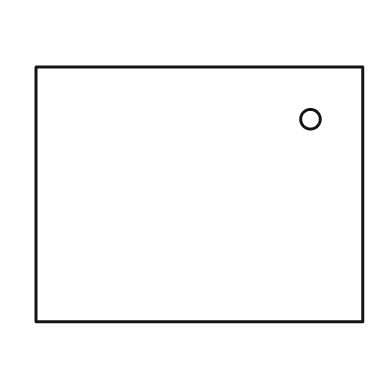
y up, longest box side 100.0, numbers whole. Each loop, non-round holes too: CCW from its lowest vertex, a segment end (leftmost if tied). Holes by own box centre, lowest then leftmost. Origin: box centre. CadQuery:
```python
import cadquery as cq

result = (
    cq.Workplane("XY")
    .moveTo(-50.0, -39.0)
    .lineTo(50.0, -39.0)
    .lineTo(50.0, 39.0)
    .lineTo(-50.0, 39.0)
    .close()
    .moveTo(34.0, 23.0)
    .circle(3.0)
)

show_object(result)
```